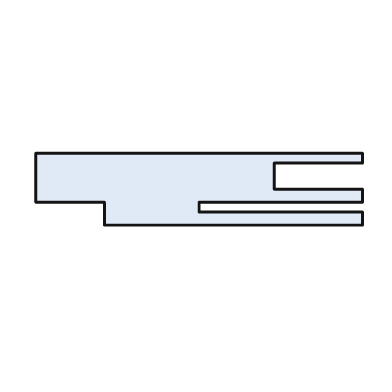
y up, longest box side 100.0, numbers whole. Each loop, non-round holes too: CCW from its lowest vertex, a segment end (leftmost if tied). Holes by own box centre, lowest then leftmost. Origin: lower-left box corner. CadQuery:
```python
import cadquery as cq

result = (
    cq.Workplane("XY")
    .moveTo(21.0, 0.0)
    .lineTo(100.0, 0.0)
    .lineTo(100.0, 4.0)
    .lineTo(50.0, 4.0)
    .lineTo(50.0, 7.0)
    .lineTo(100.0, 7.0)
    .lineTo(100.0, 11.0)
    .lineTo(73.0, 11.0)
    .lineTo(73.0, 19.0)
    .lineTo(100.0, 19.0)
    .lineTo(100.0, 22.0)
    .lineTo(0.0, 22.0)
    .lineTo(0.0, 7.0)
    .lineTo(21.0, 7.0)
    .close()
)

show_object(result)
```